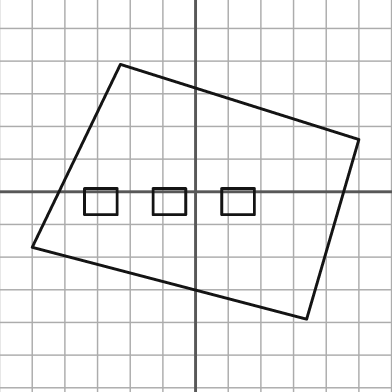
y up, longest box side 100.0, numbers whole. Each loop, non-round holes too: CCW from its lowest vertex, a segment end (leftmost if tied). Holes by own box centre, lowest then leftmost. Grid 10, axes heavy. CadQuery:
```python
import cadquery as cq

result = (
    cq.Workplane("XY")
    .moveTo(34.0, -39.0)
    .lineTo(50.0, 16.0)
    .lineTo(-23.0, 39.0)
    .lineTo(-50.0, -17.0)
    .close()
    .moveTo(-34.0, -7.0)
    .lineTo(-24.0, -7.0)
    .lineTo(-24.0, 1.0)
    .lineTo(-34.0, 1.0)
    .close()
    .moveTo(-13.0, -7.0)
    .lineTo(-3.0, -7.0)
    .lineTo(-3.0, 1.0)
    .lineTo(-13.0, 1.0)
    .close()
    .moveTo(8.0, -7.0)
    .lineTo(18.0, -7.0)
    .lineTo(18.0, 1.0)
    .lineTo(8.0, 1.0)
    .close()
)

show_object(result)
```